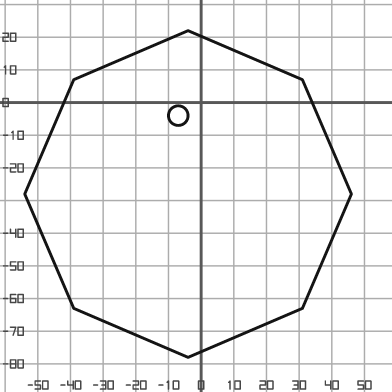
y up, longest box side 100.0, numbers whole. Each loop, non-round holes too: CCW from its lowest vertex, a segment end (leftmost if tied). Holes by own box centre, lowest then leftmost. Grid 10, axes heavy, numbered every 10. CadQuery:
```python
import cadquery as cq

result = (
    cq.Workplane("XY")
    .moveTo(-4.0, -78.0)
    .lineTo(31.0, -63.0)
    .lineTo(46.0, -28.0)
    .lineTo(31.0, 7.0)
    .lineTo(-4.0, 22.0)
    .lineTo(-39.0, 7.0)
    .lineTo(-54.0, -28.0)
    .lineTo(-39.0, -63.0)
    .close()
    .moveTo(-7.0, -4.0)
    .circle(3.0)
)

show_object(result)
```